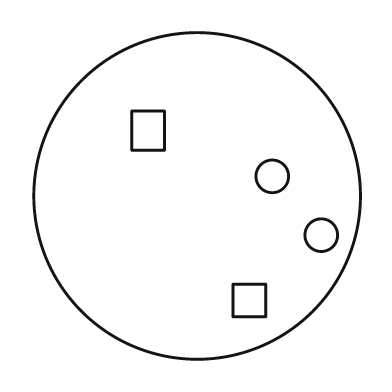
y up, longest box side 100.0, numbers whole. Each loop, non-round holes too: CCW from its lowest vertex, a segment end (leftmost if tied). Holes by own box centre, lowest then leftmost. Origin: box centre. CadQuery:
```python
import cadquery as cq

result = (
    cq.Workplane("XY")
    .moveTo(0.0, 0.0)
    .circle(50.0)
    .moveTo(11.0, -37.0)
    .lineTo(21.0, -37.0)
    .lineTo(21.0, -27.0)
    .lineTo(11.0, -27.0)
    .close()
    .moveTo(38.0, -12.0)
    .circle(5.0)
    .moveTo(23.0, 6.0)
    .circle(5.0)
    .moveTo(-20.0, 14.0)
    .lineTo(-10.0, 14.0)
    .lineTo(-10.0, 26.0)
    .lineTo(-20.0, 26.0)
    .close()
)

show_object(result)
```